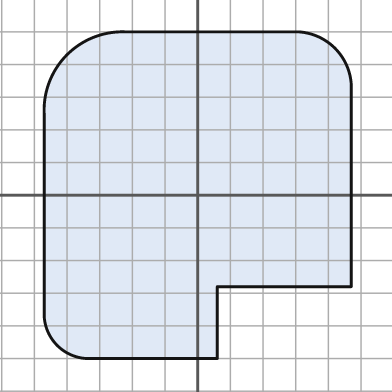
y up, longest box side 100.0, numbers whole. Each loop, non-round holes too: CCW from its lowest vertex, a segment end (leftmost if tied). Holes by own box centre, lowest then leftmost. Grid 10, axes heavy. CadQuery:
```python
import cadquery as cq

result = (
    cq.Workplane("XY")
    .moveTo(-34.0, -50.0)
    .lineTo(6.0, -50.0)
    .lineTo(6.0, -28.0)
    .lineTo(47.0, -28.0)
    .lineTo(47.0, 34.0)
    .threePointArc((42.0, 45.0), (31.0, 50.0))
    .lineTo(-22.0, 50.0)
    .threePointArc((-40.0, 43.0), (-47.0, 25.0))
    .lineTo(-47.0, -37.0)
    .threePointArc((-43.0, -46.0), (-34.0, -50.0))
    .close()
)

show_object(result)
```